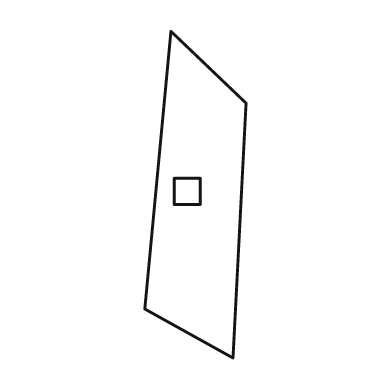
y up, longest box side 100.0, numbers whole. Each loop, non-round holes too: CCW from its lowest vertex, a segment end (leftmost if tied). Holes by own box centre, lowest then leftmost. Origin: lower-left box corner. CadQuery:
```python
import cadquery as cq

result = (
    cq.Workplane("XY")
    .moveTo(27.0, 0.0)
    .lineTo(31.0, 78.0)
    .lineTo(8.0, 100.0)
    .lineTo(0.0, 15.0)
    .close()
    .moveTo(9.0, 47.0)
    .lineTo(17.0, 47.0)
    .lineTo(17.0, 55.0)
    .lineTo(9.0, 55.0)
    .close()
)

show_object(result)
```